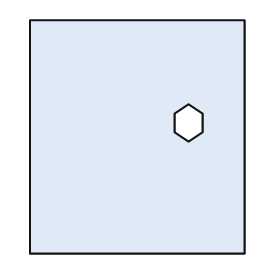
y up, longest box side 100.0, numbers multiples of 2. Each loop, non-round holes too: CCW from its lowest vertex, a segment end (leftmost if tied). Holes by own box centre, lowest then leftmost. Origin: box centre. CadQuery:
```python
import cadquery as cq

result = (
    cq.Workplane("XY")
    .moveTo(-46.0, -50.0)
    .lineTo(46.0, -50.0)
    .lineTo(46.0, 50.0)
    .lineTo(-46.0, 50.0)
    .close()
    .moveTo(22.0, -2.0)
    .lineTo(28.0, 2.0)
    .lineTo(28.0, 10.0)
    .lineTo(22.0, 14.0)
    .lineTo(16.0, 10.0)
    .lineTo(16.0, 2.0)
    .close()
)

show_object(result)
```